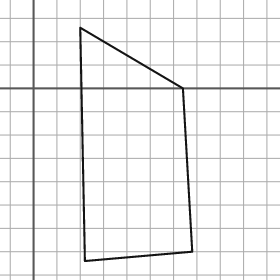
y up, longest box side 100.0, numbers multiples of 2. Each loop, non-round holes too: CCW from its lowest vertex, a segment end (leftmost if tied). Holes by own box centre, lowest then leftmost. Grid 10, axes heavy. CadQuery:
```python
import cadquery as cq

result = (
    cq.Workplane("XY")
    .moveTo(22.0, -74.0)
    .lineTo(68.0, -70.0)
    .lineTo(64.0, 0.0)
    .lineTo(20.0, 26.0)
    .close()
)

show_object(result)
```